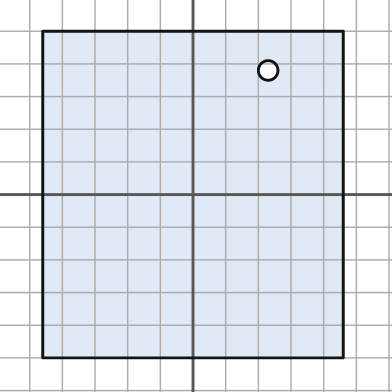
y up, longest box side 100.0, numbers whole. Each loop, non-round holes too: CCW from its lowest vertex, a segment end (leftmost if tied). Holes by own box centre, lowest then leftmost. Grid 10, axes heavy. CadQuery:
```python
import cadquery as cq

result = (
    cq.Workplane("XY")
    .moveTo(-46.0, -50.0)
    .lineTo(46.0, -50.0)
    .lineTo(46.0, 50.0)
    .lineTo(-46.0, 50.0)
    .close()
    .moveTo(23.0, 38.0)
    .circle(3.0)
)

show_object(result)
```